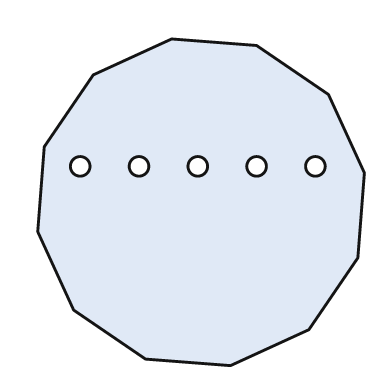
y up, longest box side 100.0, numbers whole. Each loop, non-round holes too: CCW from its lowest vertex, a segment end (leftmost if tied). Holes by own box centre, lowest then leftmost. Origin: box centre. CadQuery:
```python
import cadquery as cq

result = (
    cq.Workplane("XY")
    .moveTo(9.0, -50.0)
    .lineTo(33.0, -39.0)
    .lineTo(48.0, -17.0)
    .lineTo(50.0, 9.0)
    .lineTo(39.0, 33.0)
    .lineTo(17.0, 48.0)
    .lineTo(-9.0, 50.0)
    .lineTo(-33.0, 39.0)
    .lineTo(-48.0, 17.0)
    .lineTo(-50.0, -9.0)
    .lineTo(-39.0, -33.0)
    .lineTo(-17.0, -48.0)
    .close()
    .moveTo(-37.0, 11.0)
    .circle(3.0)
    .moveTo(-19.0, 11.0)
    .circle(3.0)
    .moveTo(-1.0, 11.0)
    .circle(3.0)
    .moveTo(17.0, 11.0)
    .circle(3.0)
    .moveTo(35.0, 11.0)
    .circle(3.0)
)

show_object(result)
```